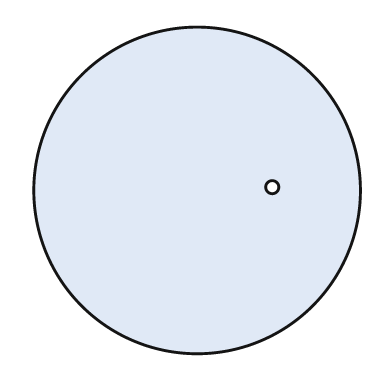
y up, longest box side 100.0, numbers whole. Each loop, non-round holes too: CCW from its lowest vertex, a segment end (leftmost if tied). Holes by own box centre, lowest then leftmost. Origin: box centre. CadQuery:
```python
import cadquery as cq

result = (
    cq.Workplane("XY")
    .moveTo(0.0, 0.0)
    .circle(50.0)
    .moveTo(23.0, 1.0)
    .circle(2.0)
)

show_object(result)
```